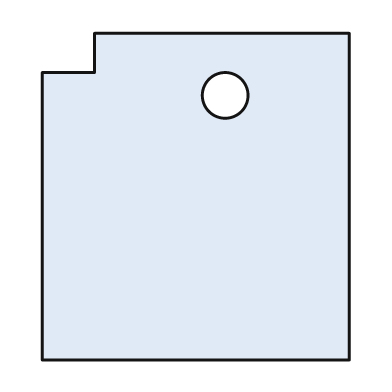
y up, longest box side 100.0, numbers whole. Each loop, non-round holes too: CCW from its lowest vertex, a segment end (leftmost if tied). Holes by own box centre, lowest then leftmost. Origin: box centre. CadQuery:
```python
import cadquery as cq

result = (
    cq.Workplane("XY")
    .moveTo(-47.0, -50.0)
    .lineTo(47.0, -50.0)
    .lineTo(47.0, 50.0)
    .lineTo(-31.0, 50.0)
    .lineTo(-31.0, 38.0)
    .lineTo(-47.0, 38.0)
    .close()
    .moveTo(9.0, 31.0)
    .circle(7.0)
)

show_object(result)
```